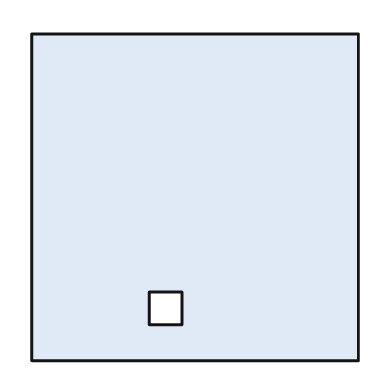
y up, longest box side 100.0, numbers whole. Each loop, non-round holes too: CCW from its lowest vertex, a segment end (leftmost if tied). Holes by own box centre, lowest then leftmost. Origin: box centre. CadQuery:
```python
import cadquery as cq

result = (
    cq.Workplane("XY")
    .moveTo(-50.0, -50.0)
    .lineTo(50.0, -50.0)
    .lineTo(50.0, 50.0)
    .lineTo(-50.0, 50.0)
    .close()
    .moveTo(-14.0, -39.0)
    .lineTo(-4.0, -39.0)
    .lineTo(-4.0, -29.0)
    .lineTo(-14.0, -29.0)
    .close()
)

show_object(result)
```